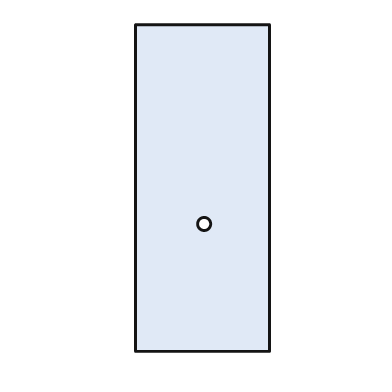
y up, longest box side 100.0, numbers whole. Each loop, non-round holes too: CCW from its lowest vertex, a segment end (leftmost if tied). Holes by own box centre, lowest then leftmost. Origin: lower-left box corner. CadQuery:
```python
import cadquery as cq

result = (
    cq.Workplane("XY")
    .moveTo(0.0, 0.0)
    .lineTo(41.0, 0.0)
    .lineTo(41.0, 100.0)
    .lineTo(0.0, 100.0)
    .close()
    .moveTo(21.0, 39.0)
    .circle(2.0)
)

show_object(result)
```